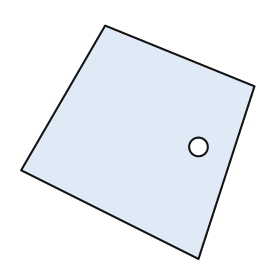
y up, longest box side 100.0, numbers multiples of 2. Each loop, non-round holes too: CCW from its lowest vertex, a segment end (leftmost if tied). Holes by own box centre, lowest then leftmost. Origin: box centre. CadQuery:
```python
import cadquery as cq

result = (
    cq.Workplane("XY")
    .moveTo(26.0, -50.0)
    .lineTo(50.0, 24.0)
    .lineTo(-14.0, 50.0)
    .lineTo(-50.0, -12.0)
    .close()
    .moveTo(26.0, -2.0)
    .circle(4.0)
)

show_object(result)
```